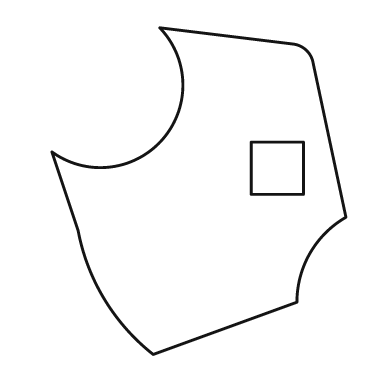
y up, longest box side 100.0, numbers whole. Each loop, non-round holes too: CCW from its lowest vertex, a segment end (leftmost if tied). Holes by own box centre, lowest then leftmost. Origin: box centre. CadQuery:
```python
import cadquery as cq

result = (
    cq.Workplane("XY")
    .moveTo(-14.0, -50.0)
    .lineTo(30.0, -34.0)
    .threePointArc((34.0, -19.0), (45.0, -8.0))
    .lineTo(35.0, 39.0)
    .threePointArc((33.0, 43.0), (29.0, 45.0))
    .lineTo(-12.0, 50.0)
    .threePointArc((-11.0, 16.0), (-45.0, 12.0))
    .lineTo(-37.0, -12.0)
    .threePointArc((-29.0, -33.0), (-14.0, -50.0))
    .close()
    .moveTo(16.0, -1.0)
    .lineTo(32.0, -1.0)
    .lineTo(32.0, 15.0)
    .lineTo(16.0, 15.0)
    .close()
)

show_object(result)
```